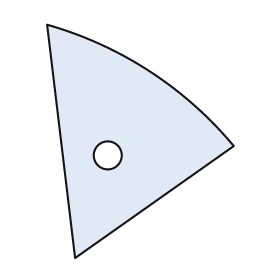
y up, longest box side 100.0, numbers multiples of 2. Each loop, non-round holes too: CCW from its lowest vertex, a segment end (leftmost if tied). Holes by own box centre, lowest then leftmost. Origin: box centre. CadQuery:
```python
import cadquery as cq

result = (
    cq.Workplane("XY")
    .moveTo(-28.0, -50.0)
    .lineTo(40.0, -2.0)
    .threePointArc((4.0, 30.0), (-40.0, 50.0))
    .close()
    .moveTo(-14.0, -6.0)
    .circle(6.0)
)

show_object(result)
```